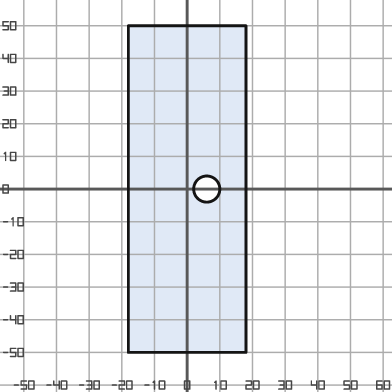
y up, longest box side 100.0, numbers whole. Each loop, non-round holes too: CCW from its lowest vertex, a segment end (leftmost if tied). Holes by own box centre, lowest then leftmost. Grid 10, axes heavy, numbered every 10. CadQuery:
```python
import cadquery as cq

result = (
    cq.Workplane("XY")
    .moveTo(-18.0, -50.0)
    .lineTo(18.0, -50.0)
    .lineTo(18.0, 50.0)
    .lineTo(-18.0, 50.0)
    .close()
    .moveTo(6.0, 0.0)
    .circle(4.0)
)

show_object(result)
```